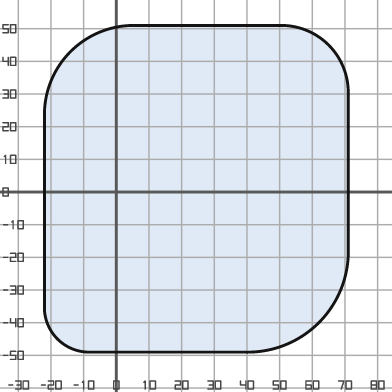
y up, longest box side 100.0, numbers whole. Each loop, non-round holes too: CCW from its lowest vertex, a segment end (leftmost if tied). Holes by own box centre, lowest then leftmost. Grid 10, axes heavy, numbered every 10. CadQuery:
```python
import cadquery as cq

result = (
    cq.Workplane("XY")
    .moveTo(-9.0, -49.0)
    .lineTo(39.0, -49.0)
    .threePointArc((62.0, -40.0), (71.0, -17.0))
    .lineTo(71.0, 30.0)
    .threePointArc((65.0, 45.0), (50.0, 51.0))
    .lineTo(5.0, 51.0)
    .threePointArc((-14.0, 43.0), (-22.0, 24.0))
    .lineTo(-22.0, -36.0)
    .threePointArc((-18.0, -45.0), (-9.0, -49.0))
    .close()
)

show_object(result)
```